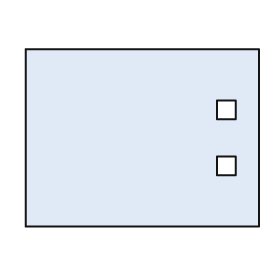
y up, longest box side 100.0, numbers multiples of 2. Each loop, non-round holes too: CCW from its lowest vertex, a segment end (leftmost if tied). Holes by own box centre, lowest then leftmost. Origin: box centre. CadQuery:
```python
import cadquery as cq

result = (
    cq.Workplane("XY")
    .moveTo(-50.0, -38.0)
    .lineTo(50.0, -38.0)
    .lineTo(50.0, 38.0)
    .lineTo(-50.0, 38.0)
    .close()
    .moveTo(32.0, -16.0)
    .lineTo(40.0, -16.0)
    .lineTo(40.0, -8.0)
    .lineTo(32.0, -8.0)
    .close()
    .moveTo(32.0, 8.0)
    .lineTo(40.0, 8.0)
    .lineTo(40.0, 16.0)
    .lineTo(32.0, 16.0)
    .close()
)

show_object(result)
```